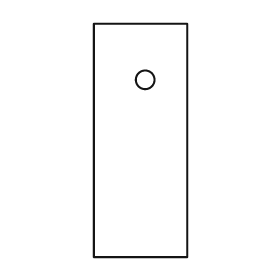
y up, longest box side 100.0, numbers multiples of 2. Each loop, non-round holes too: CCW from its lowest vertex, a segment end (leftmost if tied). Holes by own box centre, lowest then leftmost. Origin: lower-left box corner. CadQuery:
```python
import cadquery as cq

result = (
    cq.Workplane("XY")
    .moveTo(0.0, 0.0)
    .lineTo(40.0, 0.0)
    .lineTo(40.0, 100.0)
    .lineTo(0.0, 100.0)
    .close()
    .moveTo(22.0, 76.0)
    .circle(4.0)
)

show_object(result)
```